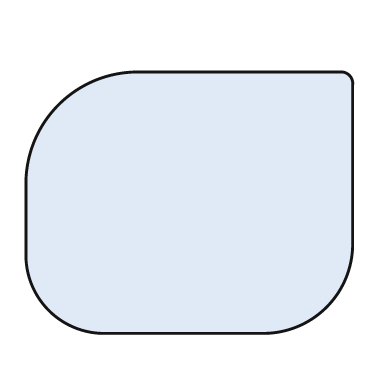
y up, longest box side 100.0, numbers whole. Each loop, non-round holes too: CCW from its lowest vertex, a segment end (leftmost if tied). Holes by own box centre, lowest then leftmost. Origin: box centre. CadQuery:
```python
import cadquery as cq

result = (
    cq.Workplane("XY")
    .moveTo(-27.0, -40.0)
    .lineTo(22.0, -40.0)
    .threePointArc((42.0, -32.0), (50.0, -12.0))
    .lineTo(50.0, 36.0)
    .threePointArc((49.0, 39.0), (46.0, 40.0))
    .lineTo(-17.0, 40.0)
    .threePointArc((-40.0, 30.0), (-50.0, 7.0))
    .lineTo(-50.0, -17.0)
    .threePointArc((-43.0, -33.0), (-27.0, -40.0))
    .close()
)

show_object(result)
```